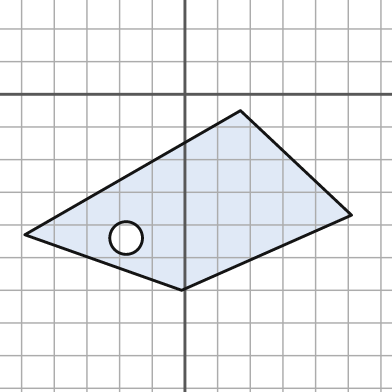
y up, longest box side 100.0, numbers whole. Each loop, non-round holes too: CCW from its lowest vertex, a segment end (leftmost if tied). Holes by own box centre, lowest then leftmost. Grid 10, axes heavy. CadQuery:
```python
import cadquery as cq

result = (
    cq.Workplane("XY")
    .moveTo(-1.0, -60.0)
    .lineTo(51.0, -37.0)
    .lineTo(17.0, -5.0)
    .lineTo(-49.0, -43.0)
    .close()
    .moveTo(-18.0, -44.0)
    .circle(5.0)
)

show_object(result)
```